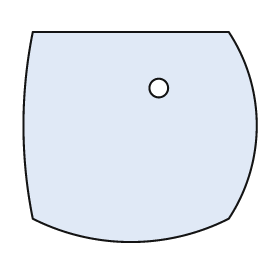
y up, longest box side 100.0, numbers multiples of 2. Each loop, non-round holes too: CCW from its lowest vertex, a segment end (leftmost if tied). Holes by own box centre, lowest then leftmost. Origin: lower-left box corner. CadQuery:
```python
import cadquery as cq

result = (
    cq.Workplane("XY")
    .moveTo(4.0, 10.0)
    .threePointArc((46.0, 0.0), (88.0, 10.0))
    .threePointArc((100.0, 50.0), (88.0, 90.0))
    .lineTo(4.0, 90.0)
    .threePointArc((0.0, 50.0), (4.0, 10.0))
    .close()
    .moveTo(58.0, 66.0)
    .circle(4.0)
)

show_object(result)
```